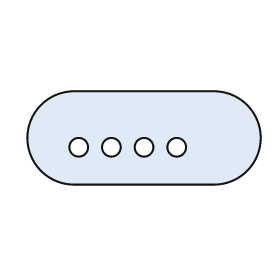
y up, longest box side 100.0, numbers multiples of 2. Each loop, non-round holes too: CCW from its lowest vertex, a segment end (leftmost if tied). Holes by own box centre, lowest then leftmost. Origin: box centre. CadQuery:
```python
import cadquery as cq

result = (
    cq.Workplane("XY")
    .moveTo(-30.0, -20.0)
    .lineTo(30.0, -20.0)
    .threePointArc((50.0, 0.0), (30.0, 20.0))
    .lineTo(-30.0, 20.0)
    .threePointArc((-50.0, 0.0), (-30.0, -20.0))
    .close()
    .moveTo(-28.0, -4.0)
    .circle(4.0)
    .moveTo(-14.0, -4.0)
    .circle(4.0)
    .moveTo(0.0, -4.0)
    .circle(4.0)
    .moveTo(14.0, -4.0)
    .circle(4.0)
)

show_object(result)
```